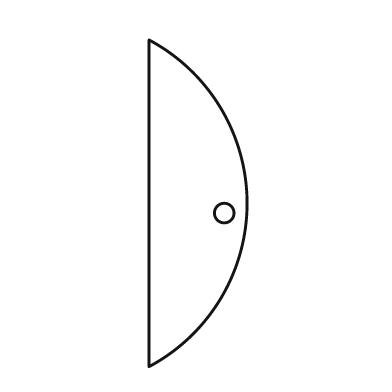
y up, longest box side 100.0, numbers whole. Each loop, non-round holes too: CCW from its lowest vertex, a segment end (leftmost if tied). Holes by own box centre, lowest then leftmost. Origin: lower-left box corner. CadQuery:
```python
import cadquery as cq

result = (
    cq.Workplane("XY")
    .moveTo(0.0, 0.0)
    .threePointArc((30.0, 50.0), (0.0, 100.0))
    .close()
    .moveTo(23.0, 47.0)
    .circle(3.0)
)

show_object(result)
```